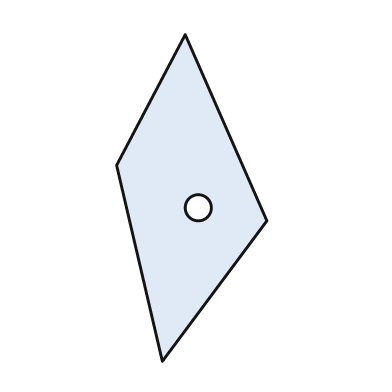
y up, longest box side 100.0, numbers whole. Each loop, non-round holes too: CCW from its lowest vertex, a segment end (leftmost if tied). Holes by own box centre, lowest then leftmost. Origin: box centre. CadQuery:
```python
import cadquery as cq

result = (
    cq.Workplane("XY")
    .moveTo(-9.0, -50.0)
    .lineTo(23.0, -7.0)
    .lineTo(-2.0, 50.0)
    .lineTo(-23.0, 10.0)
    .close()
    .moveTo(2.0, -3.0)
    .circle(4.0)
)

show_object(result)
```